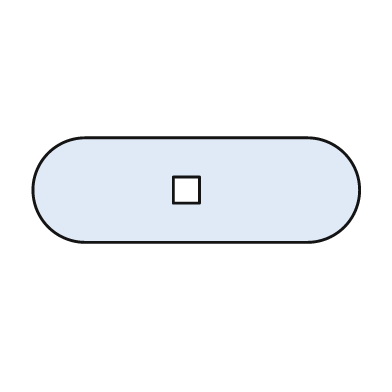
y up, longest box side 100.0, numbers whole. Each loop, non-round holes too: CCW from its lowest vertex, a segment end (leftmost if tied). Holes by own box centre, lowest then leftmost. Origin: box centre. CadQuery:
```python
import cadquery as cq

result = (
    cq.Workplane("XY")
    .moveTo(-34.0, -16.0)
    .lineTo(34.0, -16.0)
    .threePointArc((50.0, 0.0), (34.0, 16.0))
    .lineTo(-34.0, 16.0)
    .threePointArc((-50.0, 0.0), (-34.0, -16.0))
    .close()
    .moveTo(-7.0, -4.0)
    .lineTo(1.0, -4.0)
    .lineTo(1.0, 4.0)
    .lineTo(-7.0, 4.0)
    .close()
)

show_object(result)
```